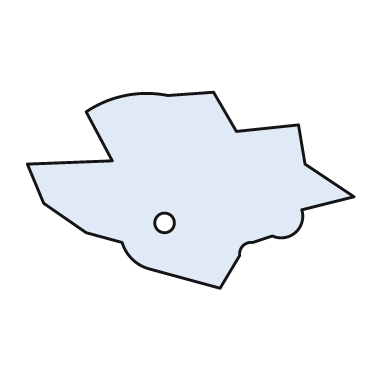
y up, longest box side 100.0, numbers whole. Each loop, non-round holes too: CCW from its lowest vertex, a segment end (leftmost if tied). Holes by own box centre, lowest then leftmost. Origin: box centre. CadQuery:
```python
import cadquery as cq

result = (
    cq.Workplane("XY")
    .moveTo(9.0, -30.0)
    .lineTo(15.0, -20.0)
    .threePointArc((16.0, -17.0), (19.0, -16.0))
    .lineTo(25.0, -14.0)
    .threePointArc((32.0, -13.0), (34.0, -6.0))
    .lineTo(50.0, -2.0)
    .lineTo(35.0, 8.0)
    .lineTo(33.0, 20.0)
    .lineTo(14.0, 18.0)
    .lineTo(7.0, 30.0)
    .lineTo(-7.0, 29.0)
    .threePointArc((-20.0, 29.0), (-32.0, 24.0))
    .lineTo(-24.0, 9.0)
    .lineTo(-50.0, 8.0)
    .lineTo(-45.0, -4.0)
    .lineTo(-32.0, -13.0)
    .lineTo(-21.0, -16.0)
    .threePointArc((-18.0, -21.0), (-13.0, -24.0))
    .close()
    .moveTo(-8.0, -10.0)
    .circle(3.0)
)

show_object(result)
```